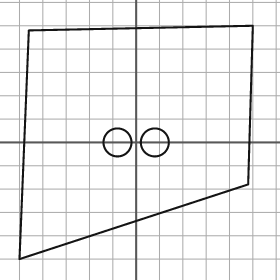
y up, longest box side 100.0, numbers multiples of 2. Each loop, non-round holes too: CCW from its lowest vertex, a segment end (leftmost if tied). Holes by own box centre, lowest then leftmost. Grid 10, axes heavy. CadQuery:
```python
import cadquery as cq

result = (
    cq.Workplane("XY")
    .moveTo(-50.0, -50.0)
    .lineTo(48.0, -18.0)
    .lineTo(50.0, 50.0)
    .lineTo(-46.0, 48.0)
    .close()
    .moveTo(-8.0, 0.0)
    .circle(6.0)
    .moveTo(8.0, 0.0)
    .circle(6.0)
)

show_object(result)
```